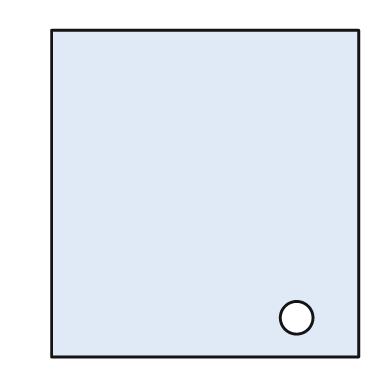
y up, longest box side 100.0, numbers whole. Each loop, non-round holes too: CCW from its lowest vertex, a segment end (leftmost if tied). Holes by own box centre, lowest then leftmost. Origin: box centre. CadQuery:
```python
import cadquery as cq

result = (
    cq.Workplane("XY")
    .moveTo(-47.0, -50.0)
    .lineTo(47.0, -50.0)
    .lineTo(47.0, 50.0)
    .lineTo(-47.0, 50.0)
    .close()
    .moveTo(28.0, -38.0)
    .circle(5.0)
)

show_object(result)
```